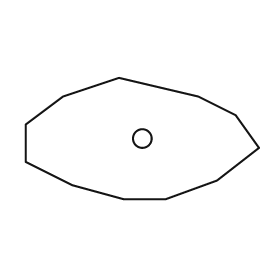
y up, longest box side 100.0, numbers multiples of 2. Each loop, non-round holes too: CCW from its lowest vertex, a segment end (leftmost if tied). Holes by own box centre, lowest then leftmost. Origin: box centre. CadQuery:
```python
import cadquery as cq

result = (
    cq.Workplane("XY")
    .moveTo(-8.0, -26.0)
    .lineTo(10.0, -26.0)
    .lineTo(32.0, -18.0)
    .lineTo(50.0, -4.0)
    .lineTo(40.0, 10.0)
    .lineTo(24.0, 18.0)
    .lineTo(-10.0, 26.0)
    .lineTo(-34.0, 18.0)
    .lineTo(-50.0, 6.0)
    .lineTo(-50.0, -10.0)
    .lineTo(-30.0, -20.0)
    .close()
    .moveTo(0.0, 0.0)
    .circle(4.0)
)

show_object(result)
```